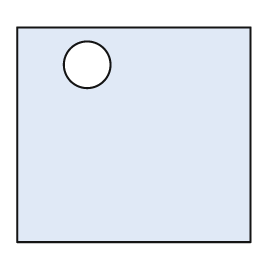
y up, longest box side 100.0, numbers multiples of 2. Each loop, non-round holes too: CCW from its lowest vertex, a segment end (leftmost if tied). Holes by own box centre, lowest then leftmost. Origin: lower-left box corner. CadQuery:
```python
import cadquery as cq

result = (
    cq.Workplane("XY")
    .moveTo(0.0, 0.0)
    .lineTo(100.0, 0.0)
    .lineTo(100.0, 92.0)
    .lineTo(0.0, 92.0)
    .close()
    .moveTo(30.0, 76.0)
    .circle(10.0)
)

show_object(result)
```